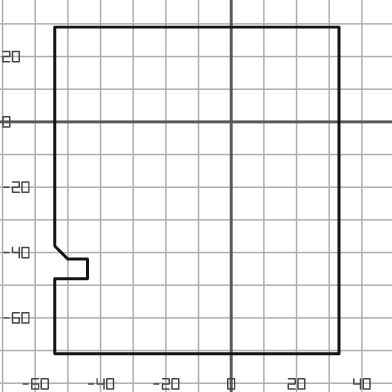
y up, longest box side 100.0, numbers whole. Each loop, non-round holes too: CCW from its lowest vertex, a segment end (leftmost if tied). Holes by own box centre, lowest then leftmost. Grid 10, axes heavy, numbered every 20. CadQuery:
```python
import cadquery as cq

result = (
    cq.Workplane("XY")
    .moveTo(-54.0, -71.0)
    .lineTo(33.0, -71.0)
    .lineTo(33.0, 29.0)
    .lineTo(-54.0, 29.0)
    .lineTo(-54.0, -38.0)
    .lineTo(-50.0, -42.0)
    .lineTo(-44.0, -42.0)
    .lineTo(-44.0, -48.0)
    .lineTo(-54.0, -48.0)
    .close()
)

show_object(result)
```